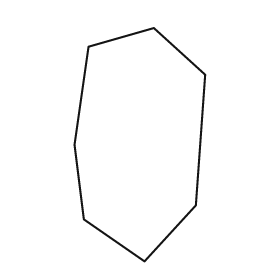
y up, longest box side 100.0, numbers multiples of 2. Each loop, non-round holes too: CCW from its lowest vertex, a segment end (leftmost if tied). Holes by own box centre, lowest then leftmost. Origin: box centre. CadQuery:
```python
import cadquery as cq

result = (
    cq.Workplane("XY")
    .moveTo(2.0, -50.0)
    .lineTo(24.0, -26.0)
    .lineTo(28.0, 30.0)
    .lineTo(6.0, 50.0)
    .lineTo(-22.0, 42.0)
    .lineTo(-28.0, 0.0)
    .lineTo(-24.0, -32.0)
    .close()
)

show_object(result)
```